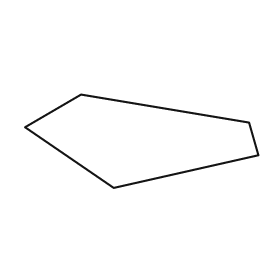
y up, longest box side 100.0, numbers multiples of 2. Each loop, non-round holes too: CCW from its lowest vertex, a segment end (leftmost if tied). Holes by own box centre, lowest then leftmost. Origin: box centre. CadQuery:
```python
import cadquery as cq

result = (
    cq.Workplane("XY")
    .moveTo(-12.0, -20.0)
    .lineTo(50.0, -6.0)
    .lineTo(46.0, 8.0)
    .lineTo(-26.0, 20.0)
    .lineTo(-50.0, 6.0)
    .close()
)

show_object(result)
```